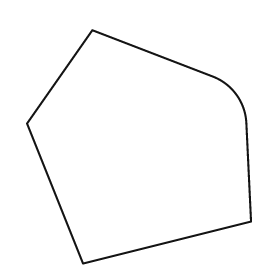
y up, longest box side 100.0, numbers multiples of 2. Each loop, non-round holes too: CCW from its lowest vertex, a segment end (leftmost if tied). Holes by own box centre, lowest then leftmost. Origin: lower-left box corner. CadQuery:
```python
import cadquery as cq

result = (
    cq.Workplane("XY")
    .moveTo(24.0, 0.0)
    .lineTo(96.0, 18.0)
    .lineTo(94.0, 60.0)
    .threePointArc((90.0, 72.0), (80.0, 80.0))
    .lineTo(28.0, 100.0)
    .lineTo(0.0, 60.0)
    .close()
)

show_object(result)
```